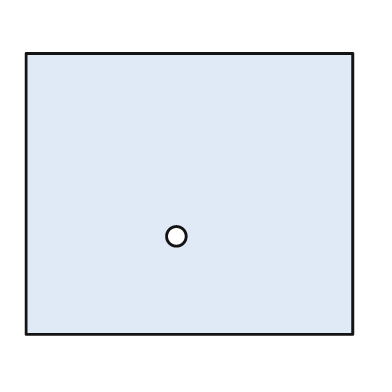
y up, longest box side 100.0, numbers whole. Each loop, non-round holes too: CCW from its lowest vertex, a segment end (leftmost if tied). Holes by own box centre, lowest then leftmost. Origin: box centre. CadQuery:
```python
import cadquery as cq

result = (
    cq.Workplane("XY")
    .moveTo(-50.0, -43.0)
    .lineTo(50.0, -43.0)
    .lineTo(50.0, 43.0)
    .lineTo(-50.0, 43.0)
    .close()
    .moveTo(-4.0, -13.0)
    .circle(3.0)
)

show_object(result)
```